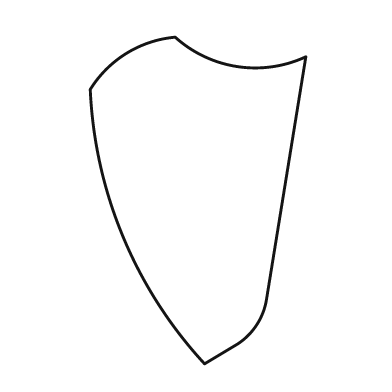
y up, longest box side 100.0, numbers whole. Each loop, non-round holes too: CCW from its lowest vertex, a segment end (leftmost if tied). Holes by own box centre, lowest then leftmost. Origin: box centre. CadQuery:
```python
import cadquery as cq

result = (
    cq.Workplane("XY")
    .moveTo(2.0, -50.0)
    .lineTo(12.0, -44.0)
    .threePointArc((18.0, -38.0), (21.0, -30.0))
    .lineTo(33.0, 44.0)
    .threePointArc((12.0, 41.0), (-7.0, 50.0))
    .threePointArc((-22.0, 45.0), (-33.0, 34.0))
    .threePointArc((-23.0, -11.0), (2.0, -50.0))
    .close()
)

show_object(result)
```